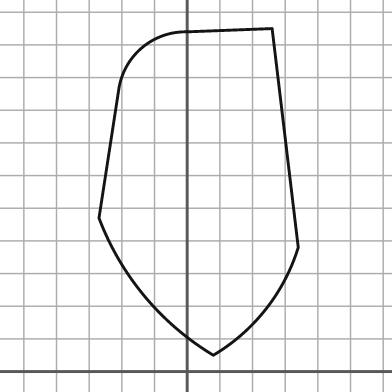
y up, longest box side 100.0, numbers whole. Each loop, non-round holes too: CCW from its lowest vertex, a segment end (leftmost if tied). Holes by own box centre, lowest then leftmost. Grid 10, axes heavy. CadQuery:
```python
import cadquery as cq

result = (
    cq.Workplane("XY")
    .moveTo(8.0, 5.0)
    .threePointArc((24.0, 19.0), (34.0, 38.0))
    .lineTo(26.0, 105.0)
    .lineTo(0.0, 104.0)
    .threePointArc((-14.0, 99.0), (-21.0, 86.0))
    .lineTo(-27.0, 47.0)
    .threePointArc((-13.0, 23.0), (8.0, 5.0))
    .close()
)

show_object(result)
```